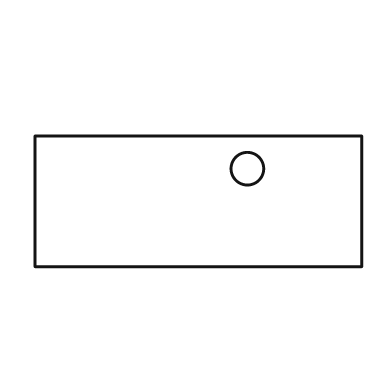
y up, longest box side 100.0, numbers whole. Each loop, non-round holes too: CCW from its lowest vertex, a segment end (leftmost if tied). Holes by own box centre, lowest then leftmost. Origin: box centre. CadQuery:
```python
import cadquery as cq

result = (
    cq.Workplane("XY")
    .moveTo(-50.0, -20.0)
    .lineTo(50.0, -20.0)
    .lineTo(50.0, 20.0)
    .lineTo(-50.0, 20.0)
    .close()
    .moveTo(15.0, 10.0)
    .circle(5.0)
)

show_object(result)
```